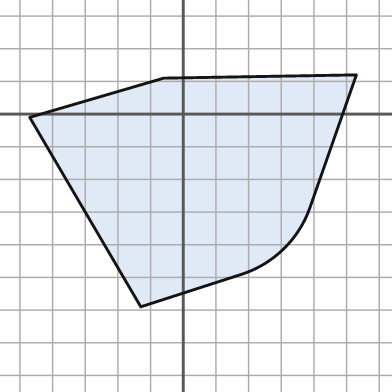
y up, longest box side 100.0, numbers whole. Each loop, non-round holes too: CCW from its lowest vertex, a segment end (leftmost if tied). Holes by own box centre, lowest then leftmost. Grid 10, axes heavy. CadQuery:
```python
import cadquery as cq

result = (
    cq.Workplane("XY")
    .moveTo(-13.0, -59.0)
    .lineTo(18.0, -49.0)
    .threePointArc((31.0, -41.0), (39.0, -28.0))
    .lineTo(53.0, 12.0)
    .lineTo(-6.0, 11.0)
    .lineTo(-47.0, -1.0)
    .close()
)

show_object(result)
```